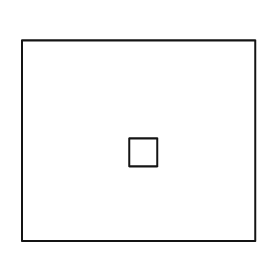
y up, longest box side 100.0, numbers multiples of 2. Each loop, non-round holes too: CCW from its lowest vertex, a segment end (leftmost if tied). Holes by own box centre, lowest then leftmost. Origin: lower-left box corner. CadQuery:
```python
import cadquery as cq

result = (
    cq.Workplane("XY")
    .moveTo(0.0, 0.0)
    .lineTo(100.0, 0.0)
    .lineTo(100.0, 86.0)
    .lineTo(0.0, 86.0)
    .close()
    .moveTo(46.0, 32.0)
    .lineTo(58.0, 32.0)
    .lineTo(58.0, 44.0)
    .lineTo(46.0, 44.0)
    .close()
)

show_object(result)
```